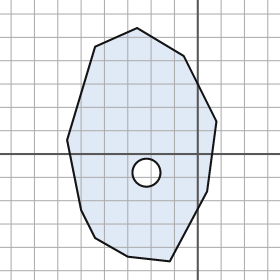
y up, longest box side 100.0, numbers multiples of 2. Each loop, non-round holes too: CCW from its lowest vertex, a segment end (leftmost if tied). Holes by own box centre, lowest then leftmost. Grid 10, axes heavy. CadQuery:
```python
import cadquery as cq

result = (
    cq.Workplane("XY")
    .moveTo(-12.0, -46.0)
    .lineTo(4.0, -16.0)
    .lineTo(8.0, 14.0)
    .lineTo(-6.0, 42.0)
    .lineTo(-26.0, 54.0)
    .lineTo(-44.0, 46.0)
    .lineTo(-56.0, 6.0)
    .lineTo(-50.0, -24.0)
    .lineTo(-44.0, -36.0)
    .lineTo(-30.0, -44.0)
    .close()
    .moveTo(-22.0, -8.0)
    .circle(6.0)
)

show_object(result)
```